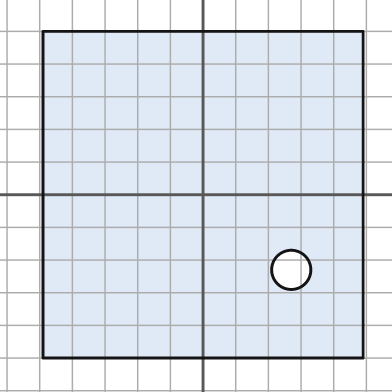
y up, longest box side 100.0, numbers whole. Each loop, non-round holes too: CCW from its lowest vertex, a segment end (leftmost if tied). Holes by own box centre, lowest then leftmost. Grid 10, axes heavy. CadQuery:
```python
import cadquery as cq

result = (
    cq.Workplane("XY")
    .moveTo(-49.0, -50.0)
    .lineTo(49.0, -50.0)
    .lineTo(49.0, 50.0)
    .lineTo(-49.0, 50.0)
    .close()
    .moveTo(27.0, -23.0)
    .circle(6.0)
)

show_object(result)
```